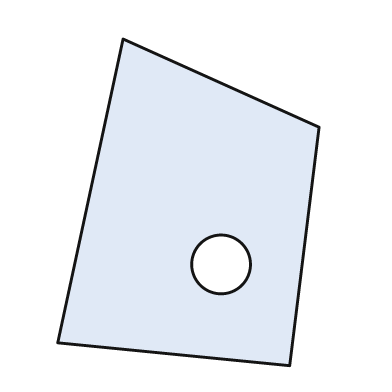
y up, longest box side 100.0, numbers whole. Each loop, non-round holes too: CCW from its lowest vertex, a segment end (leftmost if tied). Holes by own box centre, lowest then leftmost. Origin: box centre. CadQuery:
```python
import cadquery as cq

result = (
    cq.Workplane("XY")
    .moveTo(31.0, -50.0)
    .lineTo(40.0, 23.0)
    .lineTo(-20.0, 50.0)
    .lineTo(-40.0, -43.0)
    .close()
    .moveTo(10.0, -19.0)
    .circle(9.0)
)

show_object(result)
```